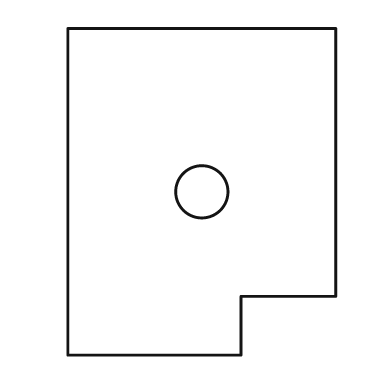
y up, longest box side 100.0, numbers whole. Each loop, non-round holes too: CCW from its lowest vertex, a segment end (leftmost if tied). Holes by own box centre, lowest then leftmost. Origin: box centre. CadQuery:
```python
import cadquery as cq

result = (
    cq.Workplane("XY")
    .moveTo(-41.0, -50.0)
    .lineTo(12.0, -50.0)
    .lineTo(12.0, -32.0)
    .lineTo(41.0, -32.0)
    .lineTo(41.0, 50.0)
    .lineTo(-41.0, 50.0)
    .close()
    .moveTo(0.0, 0.0)
    .circle(8.0)
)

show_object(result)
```